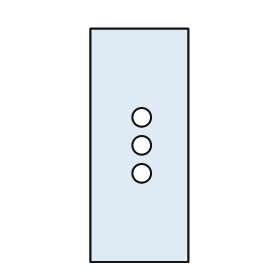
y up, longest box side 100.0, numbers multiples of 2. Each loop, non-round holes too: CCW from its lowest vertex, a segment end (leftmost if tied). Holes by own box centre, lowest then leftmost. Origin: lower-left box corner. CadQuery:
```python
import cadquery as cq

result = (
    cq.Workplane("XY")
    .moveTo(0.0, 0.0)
    .lineTo(42.0, 0.0)
    .lineTo(42.0, 100.0)
    .lineTo(0.0, 100.0)
    .close()
    .moveTo(22.0, 38.0)
    .circle(4.0)
    .moveTo(22.0, 50.0)
    .circle(4.0)
    .moveTo(22.0, 62.0)
    .circle(4.0)
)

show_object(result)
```